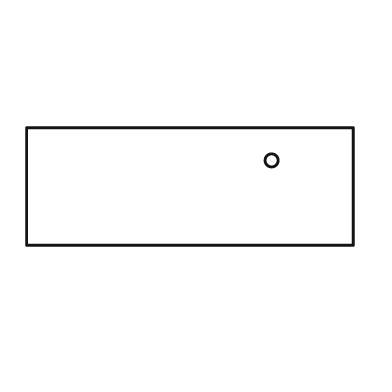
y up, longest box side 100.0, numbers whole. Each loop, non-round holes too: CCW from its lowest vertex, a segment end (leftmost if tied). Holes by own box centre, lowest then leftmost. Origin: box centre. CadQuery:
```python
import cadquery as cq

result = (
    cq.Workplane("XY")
    .moveTo(-50.0, -18.0)
    .lineTo(50.0, -18.0)
    .lineTo(50.0, 18.0)
    .lineTo(-50.0, 18.0)
    .close()
    .moveTo(25.0, 8.0)
    .circle(2.0)
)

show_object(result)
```